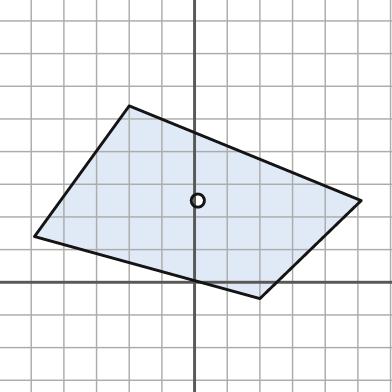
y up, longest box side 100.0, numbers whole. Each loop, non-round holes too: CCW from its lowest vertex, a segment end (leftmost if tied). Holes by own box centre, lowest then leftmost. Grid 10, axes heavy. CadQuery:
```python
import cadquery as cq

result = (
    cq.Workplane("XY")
    .moveTo(20.0, -5.0)
    .lineTo(51.0, 25.0)
    .lineTo(-20.0, 54.0)
    .lineTo(-49.0, 14.0)
    .close()
    .moveTo(1.0, 25.0)
    .circle(2.0)
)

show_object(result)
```